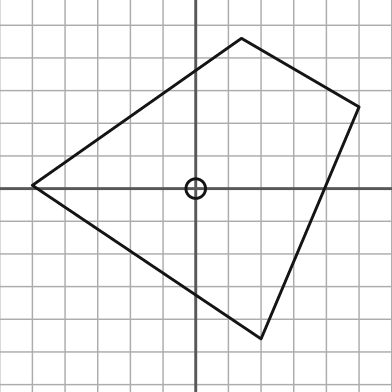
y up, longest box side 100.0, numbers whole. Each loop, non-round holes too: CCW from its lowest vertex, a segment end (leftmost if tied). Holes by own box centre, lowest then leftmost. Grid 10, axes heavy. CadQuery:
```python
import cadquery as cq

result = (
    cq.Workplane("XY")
    .moveTo(20.0, -46.0)
    .lineTo(50.0, 25.0)
    .lineTo(14.0, 46.0)
    .lineTo(-50.0, 1.0)
    .close()
    .moveTo(0.0, 0.0)
    .circle(3.0)
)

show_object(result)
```